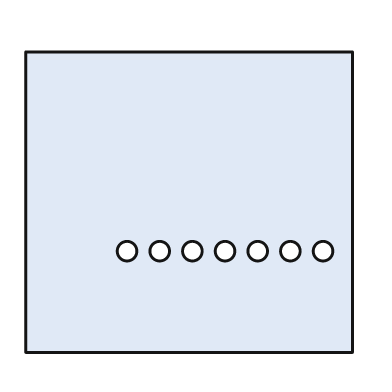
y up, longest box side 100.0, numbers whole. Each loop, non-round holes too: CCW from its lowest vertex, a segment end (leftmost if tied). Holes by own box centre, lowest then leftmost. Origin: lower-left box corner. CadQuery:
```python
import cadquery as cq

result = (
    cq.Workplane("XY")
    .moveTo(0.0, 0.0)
    .lineTo(100.0, 0.0)
    .lineTo(100.0, 92.0)
    .lineTo(0.0, 92.0)
    .close()
    .moveTo(31.0, 31.0)
    .circle(3.0)
    .moveTo(41.0, 31.0)
    .circle(3.0)
    .moveTo(51.0, 31.0)
    .circle(3.0)
    .moveTo(61.0, 31.0)
    .circle(3.0)
    .moveTo(71.0, 31.0)
    .circle(3.0)
    .moveTo(81.0, 31.0)
    .circle(3.0)
    .moveTo(91.0, 31.0)
    .circle(3.0)
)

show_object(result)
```